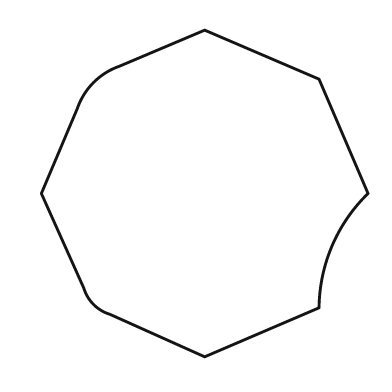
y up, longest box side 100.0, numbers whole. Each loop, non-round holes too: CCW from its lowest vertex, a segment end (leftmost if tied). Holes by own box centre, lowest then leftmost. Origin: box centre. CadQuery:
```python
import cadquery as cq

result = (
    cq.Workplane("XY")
    .moveTo(0.0, -50.0)
    .lineTo(35.0, -35.0)
    .threePointArc((39.0, -16.0), (50.0, 0.0))
    .lineTo(35.0, 35.0)
    .lineTo(0.0, 50.0)
    .lineTo(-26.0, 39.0)
    .threePointArc((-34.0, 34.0), (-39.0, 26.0))
    .lineTo(-50.0, 0.0)
    .lineTo(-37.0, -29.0)
    .threePointArc((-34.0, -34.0), (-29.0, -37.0))
    .close()
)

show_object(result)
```